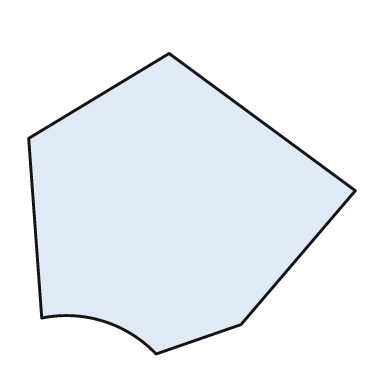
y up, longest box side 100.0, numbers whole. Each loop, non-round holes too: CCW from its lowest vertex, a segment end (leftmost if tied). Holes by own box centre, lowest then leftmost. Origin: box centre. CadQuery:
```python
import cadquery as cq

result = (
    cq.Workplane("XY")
    .moveTo(-11.0, -46.0)
    .lineTo(15.0, -37.0)
    .lineTo(50.0, 4.0)
    .lineTo(-7.0, 46.0)
    .lineTo(-50.0, 20.0)
    .lineTo(-46.0, -35.0)
    .threePointArc((-27.0, -36.0), (-11.0, -46.0))
    .close()
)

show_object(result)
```